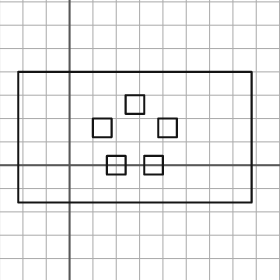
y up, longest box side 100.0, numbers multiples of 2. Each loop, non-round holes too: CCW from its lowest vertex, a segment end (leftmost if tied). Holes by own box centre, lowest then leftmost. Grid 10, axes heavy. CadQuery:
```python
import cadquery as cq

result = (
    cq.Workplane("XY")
    .moveTo(-22.0, -16.0)
    .lineTo(78.0, -16.0)
    .lineTo(78.0, 40.0)
    .lineTo(-22.0, 40.0)
    .close()
    .moveTo(16.0, -4.0)
    .lineTo(24.0, -4.0)
    .lineTo(24.0, 4.0)
    .lineTo(16.0, 4.0)
    .close()
    .moveTo(32.0, -4.0)
    .lineTo(40.0, -4.0)
    .lineTo(40.0, 4.0)
    .lineTo(32.0, 4.0)
    .close()
    .moveTo(10.0, 12.0)
    .lineTo(18.0, 12.0)
    .lineTo(18.0, 20.0)
    .lineTo(10.0, 20.0)
    .close()
    .moveTo(38.0, 12.0)
    .lineTo(46.0, 12.0)
    .lineTo(46.0, 20.0)
    .lineTo(38.0, 20.0)
    .close()
    .moveTo(24.0, 22.0)
    .lineTo(32.0, 22.0)
    .lineTo(32.0, 30.0)
    .lineTo(24.0, 30.0)
    .close()
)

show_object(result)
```